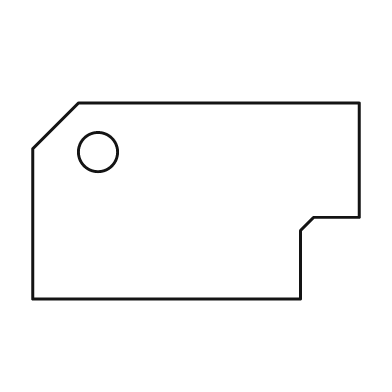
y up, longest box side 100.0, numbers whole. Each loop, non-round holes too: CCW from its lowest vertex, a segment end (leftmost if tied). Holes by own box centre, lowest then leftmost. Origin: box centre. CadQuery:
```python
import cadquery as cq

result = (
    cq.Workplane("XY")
    .moveTo(-50.0, -30.0)
    .lineTo(32.0, -30.0)
    .lineTo(32.0, -9.0)
    .lineTo(36.0, -5.0)
    .lineTo(50.0, -5.0)
    .lineTo(50.0, 30.0)
    .lineTo(-36.0, 30.0)
    .lineTo(-50.0, 16.0)
    .close()
    .moveTo(-30.0, 15.0)
    .circle(6.0)
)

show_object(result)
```